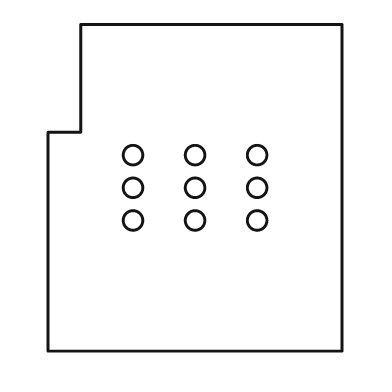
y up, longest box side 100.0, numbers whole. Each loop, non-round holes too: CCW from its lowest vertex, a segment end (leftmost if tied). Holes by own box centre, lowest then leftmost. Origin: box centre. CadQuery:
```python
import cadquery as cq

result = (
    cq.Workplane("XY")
    .moveTo(-45.0, -50.0)
    .lineTo(45.0, -50.0)
    .lineTo(45.0, 50.0)
    .lineTo(-35.0, 50.0)
    .lineTo(-35.0, 17.0)
    .lineTo(-45.0, 17.0)
    .close()
    .moveTo(-19.0, -10.0)
    .circle(3.0)
    .moveTo(0.0, -10.0)
    .circle(3.0)
    .moveTo(19.0, -10.0)
    .circle(3.0)
    .moveTo(-19.0, 0.0)
    .circle(3.0)
    .moveTo(0.0, 0.0)
    .circle(3.0)
    .moveTo(19.0, 0.0)
    .circle(3.0)
    .moveTo(-19.0, 10.0)
    .circle(3.0)
    .moveTo(0.0, 10.0)
    .circle(3.0)
    .moveTo(19.0, 10.0)
    .circle(3.0)
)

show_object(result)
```